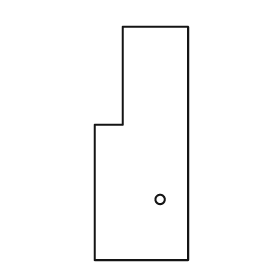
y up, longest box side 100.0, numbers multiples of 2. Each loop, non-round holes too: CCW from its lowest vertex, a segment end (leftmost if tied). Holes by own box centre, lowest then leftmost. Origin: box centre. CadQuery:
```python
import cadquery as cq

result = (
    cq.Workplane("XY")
    .moveTo(-20.0, -50.0)
    .lineTo(20.0, -50.0)
    .lineTo(20.0, 50.0)
    .lineTo(-8.0, 50.0)
    .lineTo(-8.0, 8.0)
    .lineTo(-20.0, 8.0)
    .close()
    .moveTo(8.0, -24.0)
    .circle(2.0)
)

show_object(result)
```